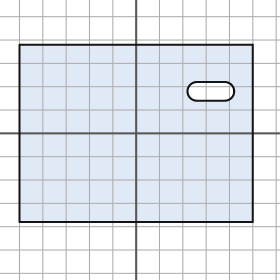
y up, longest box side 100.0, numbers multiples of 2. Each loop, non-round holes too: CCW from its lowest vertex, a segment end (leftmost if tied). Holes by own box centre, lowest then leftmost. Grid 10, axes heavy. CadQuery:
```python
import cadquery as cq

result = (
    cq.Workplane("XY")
    .moveTo(-50.0, -38.0)
    .lineTo(50.0, -38.0)
    .lineTo(50.0, 38.0)
    .lineTo(-50.0, 38.0)
    .close()
    .moveTo(26.0, 14.0)
    .lineTo(38.0, 14.0)
    .threePointArc((42.0, 18.0), (38.0, 22.0))
    .lineTo(26.0, 22.0)
    .threePointArc((22.0, 18.0), (26.0, 14.0))
    .close()
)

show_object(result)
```